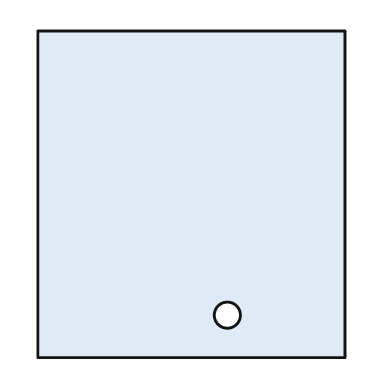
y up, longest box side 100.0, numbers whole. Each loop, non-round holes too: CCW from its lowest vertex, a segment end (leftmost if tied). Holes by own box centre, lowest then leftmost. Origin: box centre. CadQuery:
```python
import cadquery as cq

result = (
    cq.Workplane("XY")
    .moveTo(-47.0, -50.0)
    .lineTo(47.0, -50.0)
    .lineTo(47.0, 50.0)
    .lineTo(-47.0, 50.0)
    .close()
    .moveTo(11.0, -37.0)
    .circle(4.0)
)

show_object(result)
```